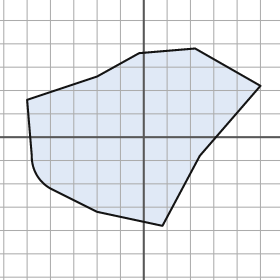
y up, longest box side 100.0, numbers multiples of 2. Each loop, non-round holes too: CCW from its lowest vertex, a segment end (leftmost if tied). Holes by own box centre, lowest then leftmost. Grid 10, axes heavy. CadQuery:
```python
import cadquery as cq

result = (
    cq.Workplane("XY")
    .moveTo(8.0, -38.0)
    .lineTo(24.0, -8.0)
    .lineTo(50.0, 22.0)
    .lineTo(22.0, 38.0)
    .lineTo(-2.0, 36.0)
    .lineTo(-20.0, 26.0)
    .lineTo(-50.0, 16.0)
    .lineTo(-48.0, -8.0)
    .threePointArc((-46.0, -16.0), (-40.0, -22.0))
    .lineTo(-20.0, -32.0)
    .close()
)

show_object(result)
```